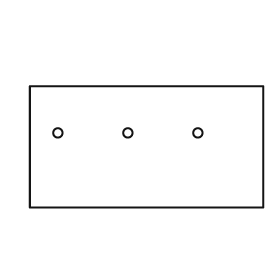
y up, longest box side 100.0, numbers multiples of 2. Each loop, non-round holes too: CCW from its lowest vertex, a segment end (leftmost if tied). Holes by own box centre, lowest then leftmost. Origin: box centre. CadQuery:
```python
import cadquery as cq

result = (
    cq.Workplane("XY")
    .moveTo(-50.0, -26.0)
    .lineTo(50.0, -26.0)
    .lineTo(50.0, 26.0)
    .lineTo(-50.0, 26.0)
    .close()
    .moveTo(-38.0, 6.0)
    .circle(2.0)
    .moveTo(-8.0, 6.0)
    .circle(2.0)
    .moveTo(22.0, 6.0)
    .circle(2.0)
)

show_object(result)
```